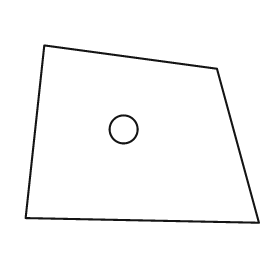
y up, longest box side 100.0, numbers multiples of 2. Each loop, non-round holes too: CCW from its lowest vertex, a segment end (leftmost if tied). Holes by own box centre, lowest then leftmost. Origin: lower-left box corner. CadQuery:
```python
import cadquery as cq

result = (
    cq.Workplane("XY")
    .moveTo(100.0, 0.0)
    .lineTo(82.0, 66.0)
    .lineTo(8.0, 76.0)
    .lineTo(0.0, 2.0)
    .close()
    .moveTo(42.0, 40.0)
    .circle(6.0)
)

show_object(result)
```